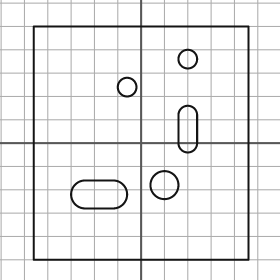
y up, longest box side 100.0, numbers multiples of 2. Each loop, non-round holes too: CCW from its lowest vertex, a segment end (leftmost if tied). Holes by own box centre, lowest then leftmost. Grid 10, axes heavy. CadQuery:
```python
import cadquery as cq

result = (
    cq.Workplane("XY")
    .moveTo(-46.0, -50.0)
    .lineTo(46.0, -50.0)
    .lineTo(46.0, 50.0)
    .lineTo(-46.0, 50.0)
    .close()
    .moveTo(-24.0, -28.0)
    .lineTo(-12.0, -28.0)
    .threePointArc((-6.0, -22.0), (-12.0, -16.0))
    .lineTo(-24.0, -16.0)
    .threePointArc((-30.0, -22.0), (-24.0, -28.0))
    .close()
    .moveTo(10.0, -18.0)
    .circle(6.0)
    .moveTo(16.0, 0.0)
    .threePointArc((20.0, -4.0), (24.0, 0.0))
    .lineTo(24.0, 12.0)
    .threePointArc((20.0, 16.0), (16.0, 12.0))
    .close()
    .moveTo(-6.0, 24.0)
    .circle(4.0)
    .moveTo(20.0, 36.0)
    .circle(4.0)
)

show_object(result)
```